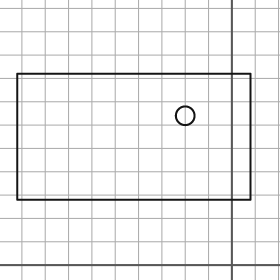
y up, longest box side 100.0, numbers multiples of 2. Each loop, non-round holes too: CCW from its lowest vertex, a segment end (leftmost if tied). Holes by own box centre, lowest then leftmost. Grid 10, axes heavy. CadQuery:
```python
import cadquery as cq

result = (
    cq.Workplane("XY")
    .moveTo(-92.0, 28.0)
    .lineTo(8.0, 28.0)
    .lineTo(8.0, 82.0)
    .lineTo(-92.0, 82.0)
    .close()
    .moveTo(-20.0, 64.0)
    .circle(4.0)
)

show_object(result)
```